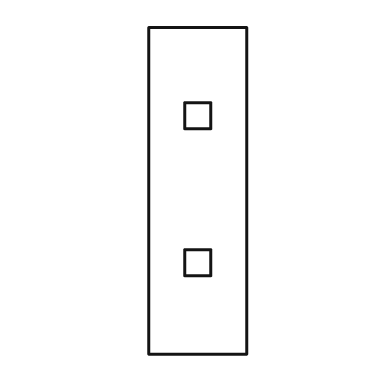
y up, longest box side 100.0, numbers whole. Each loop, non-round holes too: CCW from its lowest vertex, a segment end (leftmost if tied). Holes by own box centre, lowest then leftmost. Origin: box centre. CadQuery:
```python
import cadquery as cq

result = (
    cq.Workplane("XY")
    .moveTo(-15.0, -50.0)
    .lineTo(15.0, -50.0)
    .lineTo(15.0, 50.0)
    .lineTo(-15.0, 50.0)
    .close()
    .moveTo(-4.0, -26.0)
    .lineTo(4.0, -26.0)
    .lineTo(4.0, -18.0)
    .lineTo(-4.0, -18.0)
    .close()
    .moveTo(-4.0, 19.0)
    .lineTo(4.0, 19.0)
    .lineTo(4.0, 27.0)
    .lineTo(-4.0, 27.0)
    .close()
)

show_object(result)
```